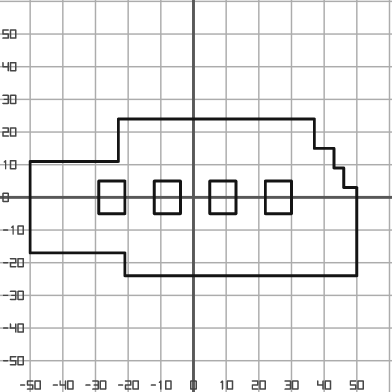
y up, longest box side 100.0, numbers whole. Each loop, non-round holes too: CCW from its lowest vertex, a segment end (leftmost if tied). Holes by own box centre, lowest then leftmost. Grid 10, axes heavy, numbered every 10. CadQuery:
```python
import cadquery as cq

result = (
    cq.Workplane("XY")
    .moveTo(-21.0, -24.0)
    .lineTo(50.0, -24.0)
    .lineTo(50.0, 3.0)
    .lineTo(46.0, 3.0)
    .lineTo(46.0, 9.0)
    .lineTo(43.0, 9.0)
    .lineTo(43.0, 15.0)
    .lineTo(37.0, 15.0)
    .lineTo(37.0, 24.0)
    .lineTo(-23.0, 24.0)
    .lineTo(-23.0, 11.0)
    .lineTo(-50.0, 11.0)
    .lineTo(-50.0, -17.0)
    .lineTo(-21.0, -17.0)
    .close()
    .moveTo(-29.0, -5.0)
    .lineTo(-21.0, -5.0)
    .lineTo(-21.0, 5.0)
    .lineTo(-29.0, 5.0)
    .close()
    .moveTo(-12.0, -5.0)
    .lineTo(-4.0, -5.0)
    .lineTo(-4.0, 5.0)
    .lineTo(-12.0, 5.0)
    .close()
    .moveTo(5.0, -5.0)
    .lineTo(13.0, -5.0)
    .lineTo(13.0, 5.0)
    .lineTo(5.0, 5.0)
    .close()
    .moveTo(22.0, -5.0)
    .lineTo(30.0, -5.0)
    .lineTo(30.0, 5.0)
    .lineTo(22.0, 5.0)
    .close()
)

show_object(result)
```